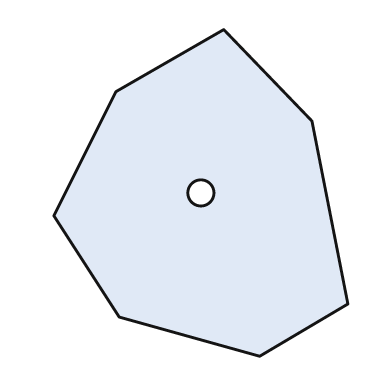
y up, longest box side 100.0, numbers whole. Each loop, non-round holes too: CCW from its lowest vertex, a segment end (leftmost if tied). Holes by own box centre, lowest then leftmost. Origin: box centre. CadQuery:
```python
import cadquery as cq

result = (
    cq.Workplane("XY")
    .moveTo(18.0, -50.0)
    .lineTo(45.0, -34.0)
    .lineTo(34.0, 22.0)
    .lineTo(7.0, 50.0)
    .lineTo(-26.0, 31.0)
    .lineTo(-45.0, -7.0)
    .lineTo(-25.0, -38.0)
    .close()
    .moveTo(0.0, 0.0)
    .circle(4.0)
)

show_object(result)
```